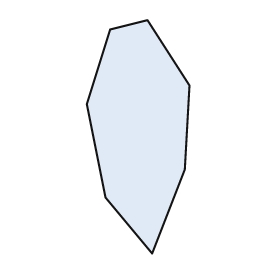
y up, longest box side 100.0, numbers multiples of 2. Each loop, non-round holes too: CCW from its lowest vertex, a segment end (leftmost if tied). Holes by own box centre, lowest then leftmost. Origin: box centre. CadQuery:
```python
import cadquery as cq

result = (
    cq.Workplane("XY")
    .moveTo(6.0, -50.0)
    .lineTo(20.0, -14.0)
    .lineTo(22.0, 22.0)
    .lineTo(4.0, 50.0)
    .lineTo(-12.0, 46.0)
    .lineTo(-22.0, 14.0)
    .lineTo(-14.0, -26.0)
    .close()
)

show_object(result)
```